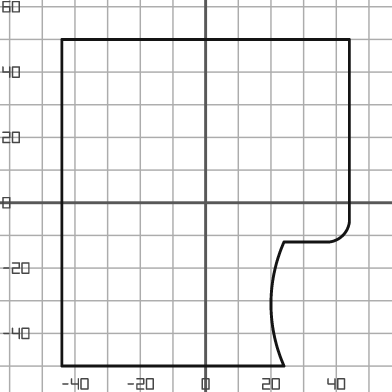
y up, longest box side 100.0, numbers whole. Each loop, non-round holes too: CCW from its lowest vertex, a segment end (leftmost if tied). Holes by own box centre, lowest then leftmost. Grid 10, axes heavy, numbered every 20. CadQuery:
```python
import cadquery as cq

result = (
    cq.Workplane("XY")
    .moveTo(-44.0, -50.0)
    .lineTo(24.0, -50.0)
    .threePointArc((20.0, -31.0), (24.0, -12.0))
    .lineTo(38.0, -12.0)
    .threePointArc((42.0, -10.0), (44.0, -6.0))
    .lineTo(44.0, 50.0)
    .lineTo(-44.0, 50.0)
    .close()
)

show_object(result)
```